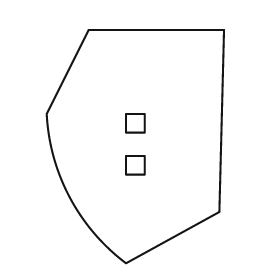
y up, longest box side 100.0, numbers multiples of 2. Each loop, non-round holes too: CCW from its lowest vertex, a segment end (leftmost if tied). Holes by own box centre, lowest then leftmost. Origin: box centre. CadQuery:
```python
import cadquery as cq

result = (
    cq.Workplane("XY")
    .moveTo(-4.0, -50.0)
    .lineTo(36.0, -28.0)
    .lineTo(38.0, 50.0)
    .lineTo(-20.0, 50.0)
    .lineTo(-38.0, 14.0)
    .threePointArc((-28.0, -22.0), (-4.0, -50.0))
    .close()
    .moveTo(-4.0, -12.0)
    .lineTo(4.0, -12.0)
    .lineTo(4.0, -4.0)
    .lineTo(-4.0, -4.0)
    .close()
    .moveTo(-4.0, 6.0)
    .lineTo(4.0, 6.0)
    .lineTo(4.0, 14.0)
    .lineTo(-4.0, 14.0)
    .close()
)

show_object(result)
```